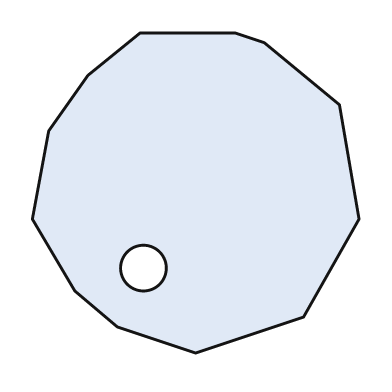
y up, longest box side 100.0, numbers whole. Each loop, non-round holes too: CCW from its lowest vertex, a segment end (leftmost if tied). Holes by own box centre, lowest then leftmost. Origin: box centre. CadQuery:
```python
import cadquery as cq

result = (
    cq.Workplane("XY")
    .moveTo(0.0, -49.0)
    .lineTo(33.0, -38.0)
    .lineTo(50.0, -8.0)
    .lineTo(44.0, 27.0)
    .lineTo(21.0, 46.0)
    .lineTo(12.0, 49.0)
    .lineTo(-17.0, 49.0)
    .lineTo(-33.0, 36.0)
    .lineTo(-45.0, 19.0)
    .lineTo(-50.0, -8.0)
    .lineTo(-37.0, -30.0)
    .lineTo(-24.0, -41.0)
    .close()
    .moveTo(-16.0, -23.0)
    .circle(7.0)
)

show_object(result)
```